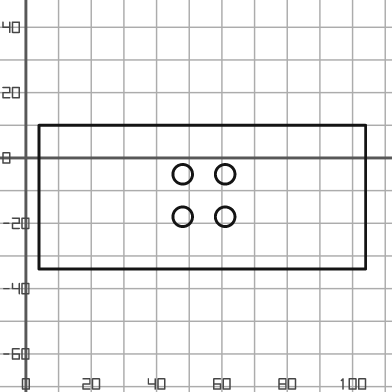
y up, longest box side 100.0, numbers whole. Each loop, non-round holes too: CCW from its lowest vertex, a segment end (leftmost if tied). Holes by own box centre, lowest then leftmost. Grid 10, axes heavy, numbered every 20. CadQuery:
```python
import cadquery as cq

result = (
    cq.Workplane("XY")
    .moveTo(4.0, -34.0)
    .lineTo(104.0, -34.0)
    .lineTo(104.0, 10.0)
    .lineTo(4.0, 10.0)
    .close()
    .moveTo(48.0, -18.0)
    .circle(3.0)
    .moveTo(61.0, -18.0)
    .circle(3.0)
    .moveTo(48.0, -5.0)
    .circle(3.0)
    .moveTo(61.0, -5.0)
    .circle(3.0)
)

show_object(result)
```